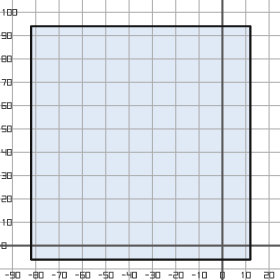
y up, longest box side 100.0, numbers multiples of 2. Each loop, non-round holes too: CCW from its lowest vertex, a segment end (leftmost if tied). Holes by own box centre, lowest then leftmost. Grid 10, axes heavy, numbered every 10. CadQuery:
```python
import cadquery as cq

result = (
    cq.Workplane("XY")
    .moveTo(-82.0, -6.0)
    .lineTo(12.0, -6.0)
    .lineTo(12.0, 94.0)
    .lineTo(-82.0, 94.0)
    .close()
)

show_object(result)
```